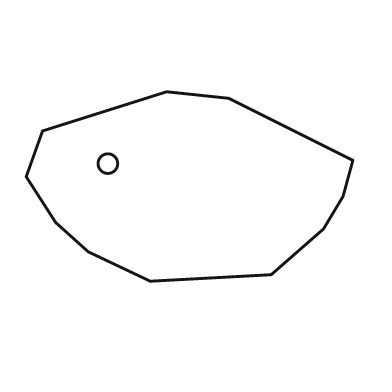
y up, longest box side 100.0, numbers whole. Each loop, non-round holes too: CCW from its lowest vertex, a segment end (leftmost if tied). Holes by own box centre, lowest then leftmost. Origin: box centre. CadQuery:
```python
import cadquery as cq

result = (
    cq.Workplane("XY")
    .moveTo(-12.0, -29.0)
    .lineTo(25.0, -27.0)
    .lineTo(41.0, -13.0)
    .lineTo(47.0, -3.0)
    .lineTo(50.0, 8.0)
    .lineTo(12.0, 27.0)
    .lineTo(-7.0, 29.0)
    .lineTo(-45.0, 17.0)
    .lineTo(-50.0, 3.0)
    .lineTo(-41.0, -11.0)
    .lineTo(-31.0, -20.0)
    .close()
    .moveTo(-25.0, 7.0)
    .circle(3.0)
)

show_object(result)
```